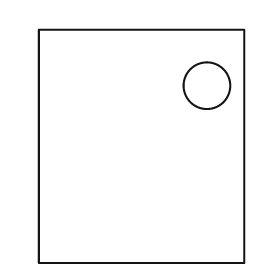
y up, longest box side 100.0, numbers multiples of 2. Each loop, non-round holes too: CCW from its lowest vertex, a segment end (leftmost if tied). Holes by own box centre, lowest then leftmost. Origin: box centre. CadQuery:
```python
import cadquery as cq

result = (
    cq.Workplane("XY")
    .moveTo(-44.0, -50.0)
    .lineTo(44.0, -50.0)
    .lineTo(44.0, 50.0)
    .lineTo(-44.0, 50.0)
    .close()
    .moveTo(28.0, 26.0)
    .circle(10.0)
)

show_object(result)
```